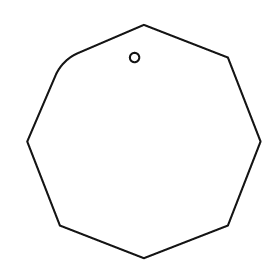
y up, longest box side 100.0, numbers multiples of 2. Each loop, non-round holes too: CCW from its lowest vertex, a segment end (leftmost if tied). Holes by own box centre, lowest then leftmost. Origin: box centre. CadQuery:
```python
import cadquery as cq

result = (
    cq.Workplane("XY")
    .moveTo(0.0, -50.0)
    .lineTo(36.0, -36.0)
    .lineTo(50.0, 0.0)
    .lineTo(36.0, 36.0)
    .lineTo(0.0, 50.0)
    .lineTo(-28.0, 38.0)
    .threePointArc((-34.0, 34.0), (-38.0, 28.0))
    .lineTo(-50.0, 0.0)
    .lineTo(-36.0, -36.0)
    .close()
    .moveTo(-4.0, 36.0)
    .circle(2.0)
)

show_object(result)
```